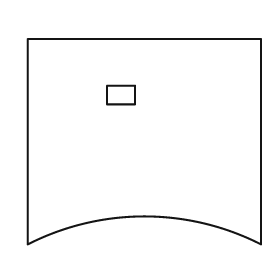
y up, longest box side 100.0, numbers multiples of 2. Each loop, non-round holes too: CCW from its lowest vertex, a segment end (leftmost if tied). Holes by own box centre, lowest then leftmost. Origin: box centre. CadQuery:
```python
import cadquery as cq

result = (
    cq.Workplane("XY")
    .moveTo(-50.0, -44.0)
    .threePointArc((0.0, -32.0), (50.0, -44.0))
    .lineTo(50.0, 44.0)
    .lineTo(-50.0, 44.0)
    .close()
    .moveTo(-16.0, 16.0)
    .lineTo(-4.0, 16.0)
    .lineTo(-4.0, 24.0)
    .lineTo(-16.0, 24.0)
    .close()
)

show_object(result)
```